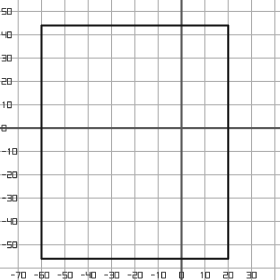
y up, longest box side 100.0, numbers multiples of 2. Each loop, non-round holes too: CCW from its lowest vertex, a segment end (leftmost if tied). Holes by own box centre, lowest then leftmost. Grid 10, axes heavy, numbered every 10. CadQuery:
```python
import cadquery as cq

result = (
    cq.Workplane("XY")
    .moveTo(-60.0, -56.0)
    .lineTo(20.0, -56.0)
    .lineTo(20.0, 44.0)
    .lineTo(-60.0, 44.0)
    .close()
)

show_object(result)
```